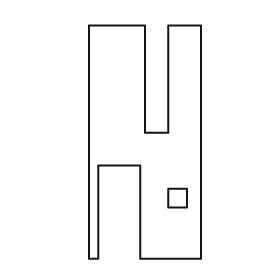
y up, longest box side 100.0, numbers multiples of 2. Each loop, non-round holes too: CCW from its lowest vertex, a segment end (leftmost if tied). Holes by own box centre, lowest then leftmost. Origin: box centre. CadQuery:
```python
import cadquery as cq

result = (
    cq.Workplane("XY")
    .moveTo(-24.0, -50.0)
    .lineTo(-20.0, -50.0)
    .lineTo(-20.0, -10.0)
    .lineTo(-2.0, -10.0)
    .lineTo(-2.0, -50.0)
    .lineTo(24.0, -50.0)
    .lineTo(24.0, 50.0)
    .lineTo(10.0, 50.0)
    .lineTo(10.0, 4.0)
    .lineTo(0.0, 4.0)
    .lineTo(0.0, 50.0)
    .lineTo(-24.0, 50.0)
    .close()
    .moveTo(10.0, -28.0)
    .lineTo(18.0, -28.0)
    .lineTo(18.0, -20.0)
    .lineTo(10.0, -20.0)
    .close()
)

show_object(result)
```